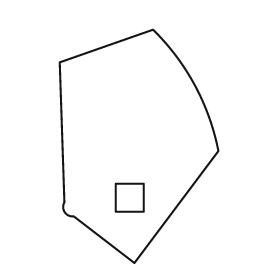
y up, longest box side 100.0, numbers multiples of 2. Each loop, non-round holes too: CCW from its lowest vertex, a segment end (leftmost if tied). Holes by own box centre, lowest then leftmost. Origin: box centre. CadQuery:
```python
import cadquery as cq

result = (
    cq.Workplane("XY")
    .moveTo(-2.0, -50.0)
    .lineTo(34.0, -2.0)
    .threePointArc((24.0, 26.0), (6.0, 50.0))
    .lineTo(-34.0, 36.0)
    .lineTo(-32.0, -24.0)
    .threePointArc((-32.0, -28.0), (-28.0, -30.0))
    .close()
    .moveTo(-10.0, -28.0)
    .lineTo(2.0, -28.0)
    .lineTo(2.0, -16.0)
    .lineTo(-10.0, -16.0)
    .close()
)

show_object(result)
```